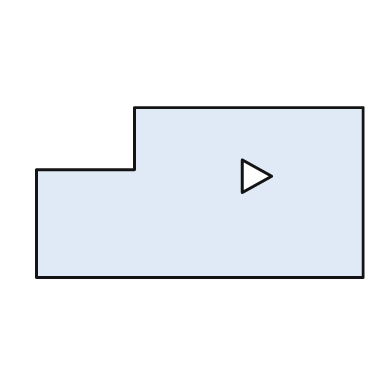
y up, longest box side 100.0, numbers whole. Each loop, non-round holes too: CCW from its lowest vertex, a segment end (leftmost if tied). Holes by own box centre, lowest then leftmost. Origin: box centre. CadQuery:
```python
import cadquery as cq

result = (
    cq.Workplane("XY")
    .moveTo(-50.0, -26.0)
    .lineTo(50.0, -26.0)
    .lineTo(50.0, 26.0)
    .lineTo(-20.0, 26.0)
    .lineTo(-20.0, 7.0)
    .lineTo(-50.0, 7.0)
    .close()
    .moveTo(13.0, 0.0)
    .lineTo(22.0, 5.0)
    .lineTo(13.0, 10.0)
    .close()
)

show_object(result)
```